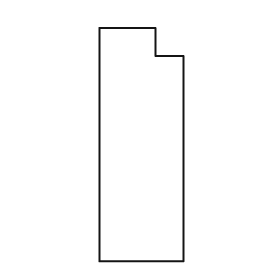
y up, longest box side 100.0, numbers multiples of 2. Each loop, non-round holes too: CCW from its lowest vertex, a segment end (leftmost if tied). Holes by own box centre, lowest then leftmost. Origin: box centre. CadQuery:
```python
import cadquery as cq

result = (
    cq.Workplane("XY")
    .moveTo(-18.0, -50.0)
    .lineTo(18.0, -50.0)
    .lineTo(18.0, 38.0)
    .lineTo(6.0, 38.0)
    .lineTo(6.0, 50.0)
    .lineTo(-18.0, 50.0)
    .close()
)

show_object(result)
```